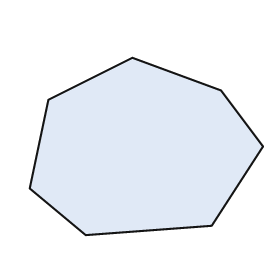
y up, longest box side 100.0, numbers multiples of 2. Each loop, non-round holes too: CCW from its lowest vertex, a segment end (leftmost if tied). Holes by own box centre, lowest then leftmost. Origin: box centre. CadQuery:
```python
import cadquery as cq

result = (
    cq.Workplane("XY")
    .moveTo(-26.0, -38.0)
    .lineTo(28.0, -34.0)
    .lineTo(50.0, 0.0)
    .lineTo(32.0, 24.0)
    .lineTo(-6.0, 38.0)
    .lineTo(-42.0, 20.0)
    .lineTo(-50.0, -18.0)
    .close()
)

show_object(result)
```